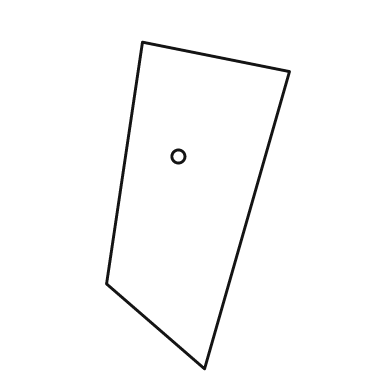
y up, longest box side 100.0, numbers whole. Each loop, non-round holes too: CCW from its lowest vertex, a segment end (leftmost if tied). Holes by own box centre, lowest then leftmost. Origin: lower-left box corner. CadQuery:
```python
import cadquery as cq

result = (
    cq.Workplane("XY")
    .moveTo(30.0, 0.0)
    .lineTo(56.0, 91.0)
    .lineTo(11.0, 100.0)
    .lineTo(0.0, 26.0)
    .close()
    .moveTo(22.0, 65.0)
    .circle(2.0)
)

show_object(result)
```